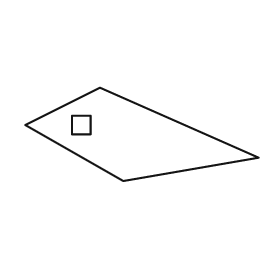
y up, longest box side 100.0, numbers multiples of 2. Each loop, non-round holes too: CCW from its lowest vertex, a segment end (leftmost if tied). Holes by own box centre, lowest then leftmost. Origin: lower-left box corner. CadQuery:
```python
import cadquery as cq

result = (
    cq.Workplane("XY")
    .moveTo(42.0, 0.0)
    .lineTo(100.0, 10.0)
    .lineTo(32.0, 40.0)
    .lineTo(0.0, 24.0)
    .close()
    .moveTo(20.0, 20.0)
    .lineTo(28.0, 20.0)
    .lineTo(28.0, 28.0)
    .lineTo(20.0, 28.0)
    .close()
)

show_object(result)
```